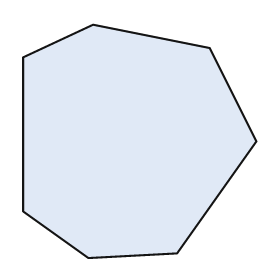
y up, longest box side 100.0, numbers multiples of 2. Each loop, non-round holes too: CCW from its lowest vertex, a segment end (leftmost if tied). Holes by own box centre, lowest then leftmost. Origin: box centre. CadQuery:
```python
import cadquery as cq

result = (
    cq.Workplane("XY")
    .moveTo(-22.0, -50.0)
    .lineTo(16.0, -48.0)
    .lineTo(50.0, 0.0)
    .lineTo(30.0, 40.0)
    .lineTo(-20.0, 50.0)
    .lineTo(-50.0, 36.0)
    .lineTo(-50.0, -30.0)
    .close()
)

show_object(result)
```